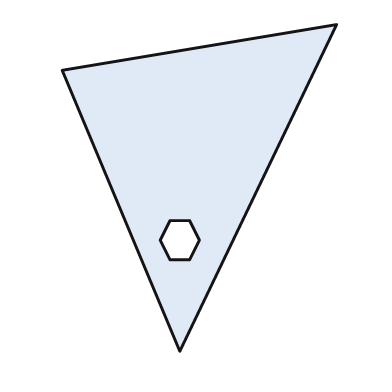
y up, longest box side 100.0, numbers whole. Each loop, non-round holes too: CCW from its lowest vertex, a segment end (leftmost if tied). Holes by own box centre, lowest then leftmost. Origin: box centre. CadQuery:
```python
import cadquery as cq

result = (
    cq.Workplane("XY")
    .moveTo(-6.0, -50.0)
    .lineTo(42.0, 50.0)
    .lineTo(-42.0, 36.0)
    .close()
    .moveTo(-9.0, -22.0)
    .lineTo(-3.0, -22.0)
    .lineTo(0.0, -16.0)
    .lineTo(-3.0, -10.0)
    .lineTo(-9.0, -10.0)
    .lineTo(-12.0, -16.0)
    .close()
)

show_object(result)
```